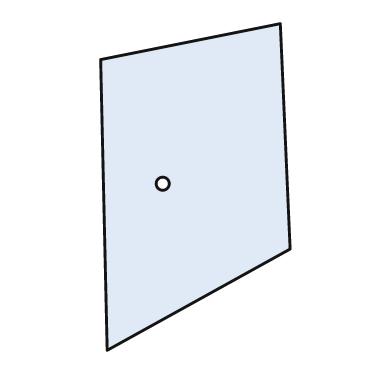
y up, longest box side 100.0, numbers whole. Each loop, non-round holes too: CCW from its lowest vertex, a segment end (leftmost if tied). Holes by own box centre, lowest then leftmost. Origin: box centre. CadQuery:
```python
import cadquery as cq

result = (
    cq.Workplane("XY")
    .moveTo(-27.0, -50.0)
    .lineTo(29.0, -19.0)
    .lineTo(26.0, 50.0)
    .lineTo(-29.0, 39.0)
    .close()
    .moveTo(-10.0, 1.0)
    .circle(2.0)
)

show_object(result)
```